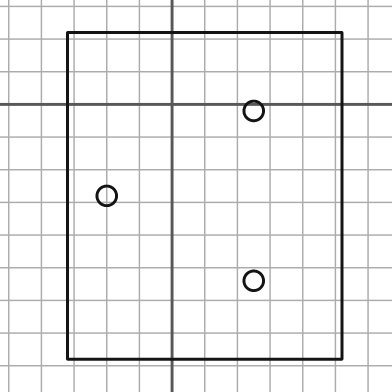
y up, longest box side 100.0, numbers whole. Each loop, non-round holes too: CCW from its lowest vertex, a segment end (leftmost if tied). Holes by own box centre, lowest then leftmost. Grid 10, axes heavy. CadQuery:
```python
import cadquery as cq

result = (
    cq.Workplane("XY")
    .moveTo(-32.0, -78.0)
    .lineTo(52.0, -78.0)
    .lineTo(52.0, 22.0)
    .lineTo(-32.0, 22.0)
    .close()
    .moveTo(25.0, -54.0)
    .circle(3.0)
    .moveTo(-20.0, -28.0)
    .circle(3.0)
    .moveTo(25.0, -2.0)
    .circle(3.0)
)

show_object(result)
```